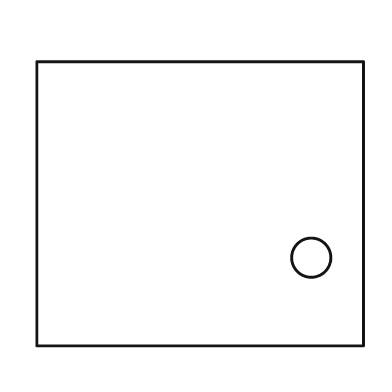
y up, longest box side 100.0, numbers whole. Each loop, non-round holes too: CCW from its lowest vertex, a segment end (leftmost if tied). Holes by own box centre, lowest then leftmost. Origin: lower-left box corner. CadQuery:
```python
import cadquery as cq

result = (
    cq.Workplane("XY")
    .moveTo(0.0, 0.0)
    .lineTo(100.0, 0.0)
    .lineTo(100.0, 87.0)
    .lineTo(0.0, 87.0)
    .close()
    .moveTo(84.0, 27.0)
    .circle(6.0)
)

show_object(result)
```